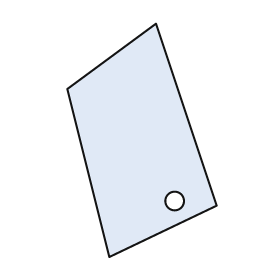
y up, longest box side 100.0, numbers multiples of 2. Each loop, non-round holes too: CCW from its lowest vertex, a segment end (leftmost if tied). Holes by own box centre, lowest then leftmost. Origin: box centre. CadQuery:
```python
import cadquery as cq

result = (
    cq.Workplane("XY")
    .moveTo(-14.0, -50.0)
    .lineTo(32.0, -28.0)
    .lineTo(6.0, 50.0)
    .lineTo(-32.0, 22.0)
    .close()
    .moveTo(14.0, -26.0)
    .circle(4.0)
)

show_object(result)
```